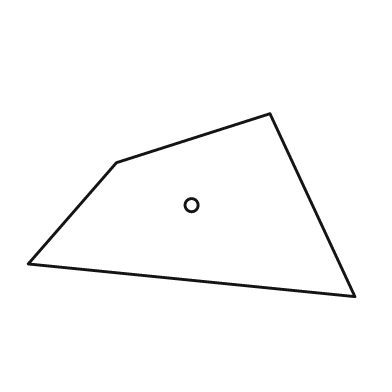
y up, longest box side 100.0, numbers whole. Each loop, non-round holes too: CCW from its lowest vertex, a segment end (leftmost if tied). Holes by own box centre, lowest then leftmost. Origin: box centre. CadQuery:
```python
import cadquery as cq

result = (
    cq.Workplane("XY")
    .moveTo(50.0, -28.0)
    .lineTo(24.0, 28.0)
    .lineTo(-23.0, 13.0)
    .lineTo(-50.0, -18.0)
    .close()
    .moveTo(0.0, 0.0)
    .circle(2.0)
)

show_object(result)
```